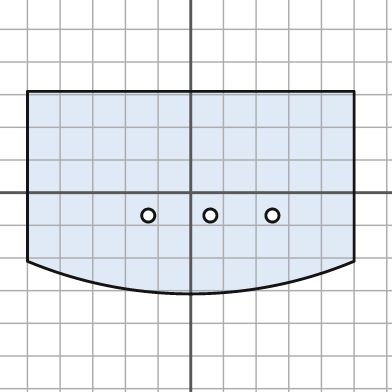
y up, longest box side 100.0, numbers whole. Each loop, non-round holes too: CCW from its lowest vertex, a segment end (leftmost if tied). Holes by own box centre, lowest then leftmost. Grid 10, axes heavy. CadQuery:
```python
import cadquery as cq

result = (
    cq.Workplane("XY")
    .moveTo(-50.0, -21.0)
    .threePointArc((0.0, -31.0), (50.0, -21.0))
    .lineTo(50.0, 31.0)
    .lineTo(-50.0, 31.0)
    .close()
    .moveTo(-13.0, -7.0)
    .circle(2.0)
    .moveTo(6.0, -7.0)
    .circle(2.0)
    .moveTo(25.0, -7.0)
    .circle(2.0)
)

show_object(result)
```